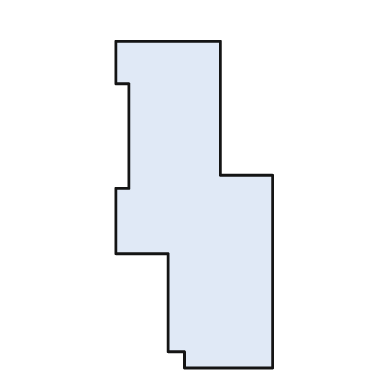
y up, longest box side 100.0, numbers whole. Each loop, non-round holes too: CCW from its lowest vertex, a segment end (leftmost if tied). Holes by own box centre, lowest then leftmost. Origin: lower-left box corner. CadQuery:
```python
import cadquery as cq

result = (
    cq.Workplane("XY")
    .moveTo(21.0, 0.0)
    .lineTo(48.0, 0.0)
    .lineTo(48.0, 59.0)
    .lineTo(32.0, 59.0)
    .lineTo(32.0, 100.0)
    .lineTo(0.0, 100.0)
    .lineTo(0.0, 87.0)
    .lineTo(4.0, 87.0)
    .lineTo(4.0, 55.0)
    .lineTo(0.0, 55.0)
    .lineTo(0.0, 35.0)
    .lineTo(16.0, 35.0)
    .lineTo(16.0, 5.0)
    .lineTo(21.0, 5.0)
    .close()
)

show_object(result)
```